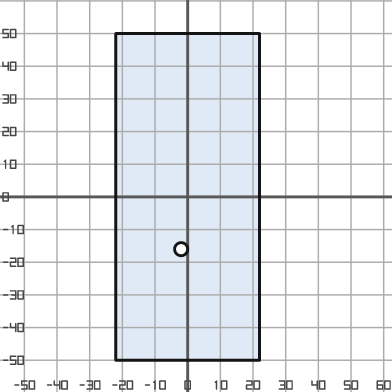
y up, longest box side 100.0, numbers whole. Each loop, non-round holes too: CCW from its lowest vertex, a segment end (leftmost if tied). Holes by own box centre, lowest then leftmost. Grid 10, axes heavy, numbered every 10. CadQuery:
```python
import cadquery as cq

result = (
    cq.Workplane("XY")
    .moveTo(-22.0, -50.0)
    .lineTo(22.0, -50.0)
    .lineTo(22.0, 50.0)
    .lineTo(-22.0, 50.0)
    .close()
    .moveTo(-2.0, -16.0)
    .circle(2.0)
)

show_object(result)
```